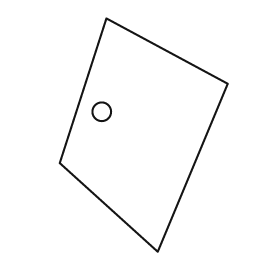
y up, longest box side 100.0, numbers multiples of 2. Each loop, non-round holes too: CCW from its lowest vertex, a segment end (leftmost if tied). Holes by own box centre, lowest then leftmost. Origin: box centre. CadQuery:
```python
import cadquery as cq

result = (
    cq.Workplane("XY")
    .moveTo(6.0, -50.0)
    .lineTo(36.0, 22.0)
    .lineTo(-16.0, 50.0)
    .lineTo(-36.0, -12.0)
    .close()
    .moveTo(-18.0, 10.0)
    .circle(4.0)
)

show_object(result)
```